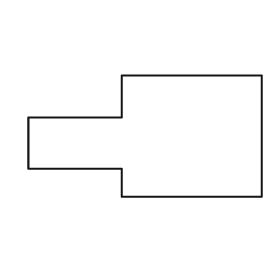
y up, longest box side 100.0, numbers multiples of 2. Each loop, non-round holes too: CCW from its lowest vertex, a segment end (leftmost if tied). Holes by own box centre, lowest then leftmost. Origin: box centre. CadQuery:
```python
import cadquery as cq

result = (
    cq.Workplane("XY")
    .moveTo(-10.0, -26.0)
    .lineTo(50.0, -26.0)
    .lineTo(50.0, 26.0)
    .lineTo(-10.0, 26.0)
    .lineTo(-10.0, 8.0)
    .lineTo(-50.0, 8.0)
    .lineTo(-50.0, -14.0)
    .lineTo(-10.0, -14.0)
    .close()
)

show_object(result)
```